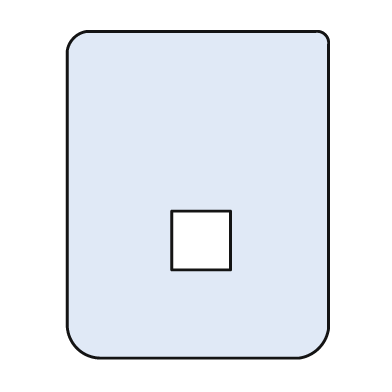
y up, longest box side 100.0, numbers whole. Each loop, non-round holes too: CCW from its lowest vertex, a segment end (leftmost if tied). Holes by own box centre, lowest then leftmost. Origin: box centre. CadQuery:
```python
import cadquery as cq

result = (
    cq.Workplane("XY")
    .moveTo(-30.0, -50.0)
    .lineTo(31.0, -50.0)
    .threePointArc((37.0, -47.0), (40.0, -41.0))
    .lineTo(40.0, 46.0)
    .threePointArc((39.0, 49.0), (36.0, 50.0))
    .lineTo(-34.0, 50.0)
    .threePointArc((-38.0, 48.0), (-40.0, 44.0))
    .lineTo(-40.0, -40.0)
    .threePointArc((-37.0, -47.0), (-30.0, -50.0))
    .close()
    .moveTo(-8.0, -23.0)
    .lineTo(10.0, -23.0)
    .lineTo(10.0, -5.0)
    .lineTo(-8.0, -5.0)
    .close()
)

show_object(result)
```